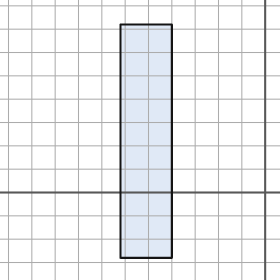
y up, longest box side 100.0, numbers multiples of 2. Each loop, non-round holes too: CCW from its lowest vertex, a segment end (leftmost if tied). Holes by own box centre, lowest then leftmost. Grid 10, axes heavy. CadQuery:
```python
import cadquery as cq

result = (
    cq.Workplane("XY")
    .moveTo(-62.0, -28.0)
    .lineTo(-40.0, -28.0)
    .lineTo(-40.0, 72.0)
    .lineTo(-62.0, 72.0)
    .close()
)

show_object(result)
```